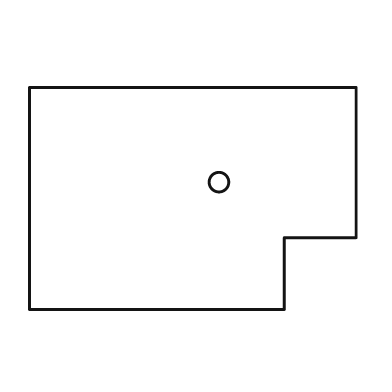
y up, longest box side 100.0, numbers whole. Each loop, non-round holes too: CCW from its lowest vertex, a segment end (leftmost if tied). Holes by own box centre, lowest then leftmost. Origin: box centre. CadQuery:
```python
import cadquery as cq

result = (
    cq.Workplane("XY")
    .moveTo(-50.0, -34.0)
    .lineTo(28.0, -34.0)
    .lineTo(28.0, -12.0)
    .lineTo(50.0, -12.0)
    .lineTo(50.0, 34.0)
    .lineTo(-50.0, 34.0)
    .close()
    .moveTo(8.0, 5.0)
    .circle(3.0)
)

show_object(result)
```